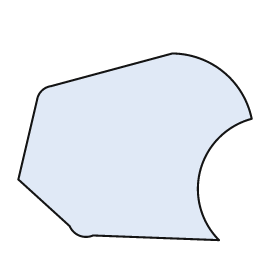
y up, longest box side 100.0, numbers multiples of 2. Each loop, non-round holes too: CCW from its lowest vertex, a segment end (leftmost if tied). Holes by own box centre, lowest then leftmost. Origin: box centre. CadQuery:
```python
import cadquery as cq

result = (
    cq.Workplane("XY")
    .moveTo(36.0, -40.0)
    .threePointArc((28.0, -10.0), (50.0, 12.0))
    .threePointArc((38.0, 32.0), (16.0, 40.0))
    .lineTo(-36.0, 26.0)
    .threePointArc((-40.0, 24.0), (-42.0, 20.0))
    .lineTo(-50.0, -14.0)
    .lineTo(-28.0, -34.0)
    .threePointArc((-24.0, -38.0), (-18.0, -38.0))
    .close()
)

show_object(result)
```